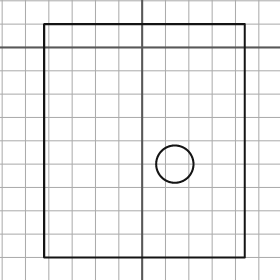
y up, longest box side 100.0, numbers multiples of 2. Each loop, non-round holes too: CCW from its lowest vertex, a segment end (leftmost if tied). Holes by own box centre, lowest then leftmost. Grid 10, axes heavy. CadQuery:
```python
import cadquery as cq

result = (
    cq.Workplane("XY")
    .moveTo(-42.0, -90.0)
    .lineTo(44.0, -90.0)
    .lineTo(44.0, 10.0)
    .lineTo(-42.0, 10.0)
    .close()
    .moveTo(14.0, -50.0)
    .circle(8.0)
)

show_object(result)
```